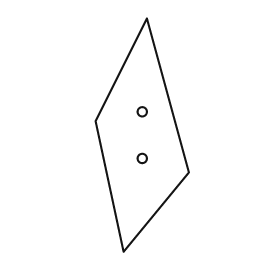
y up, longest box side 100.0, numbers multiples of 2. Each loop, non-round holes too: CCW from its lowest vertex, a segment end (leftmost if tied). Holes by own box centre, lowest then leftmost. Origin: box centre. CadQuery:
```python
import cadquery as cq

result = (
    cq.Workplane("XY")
    .moveTo(-8.0, -50.0)
    .lineTo(20.0, -16.0)
    .lineTo(2.0, 50.0)
    .lineTo(-20.0, 6.0)
    .close()
    .moveTo(0.0, -10.0)
    .circle(2.0)
    .moveTo(0.0, 10.0)
    .circle(2.0)
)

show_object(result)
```